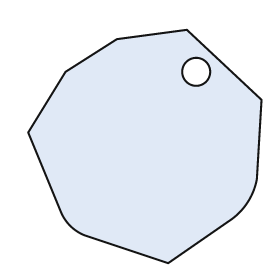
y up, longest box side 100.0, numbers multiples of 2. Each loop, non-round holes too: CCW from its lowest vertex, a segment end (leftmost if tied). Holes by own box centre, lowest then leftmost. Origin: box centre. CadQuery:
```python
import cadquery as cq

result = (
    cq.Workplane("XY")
    .moveTo(10.0, -50.0)
    .lineTo(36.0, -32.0)
    .threePointArc((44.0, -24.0), (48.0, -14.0))
    .lineTo(50.0, 20.0)
    .lineTo(18.0, 50.0)
    .lineTo(-12.0, 46.0)
    .lineTo(-34.0, 32.0)
    .lineTo(-50.0, 6.0)
    .lineTo(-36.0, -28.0)
    .threePointArc((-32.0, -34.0), (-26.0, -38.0))
    .close()
    .moveTo(22.0, 32.0)
    .circle(6.0)
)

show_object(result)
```